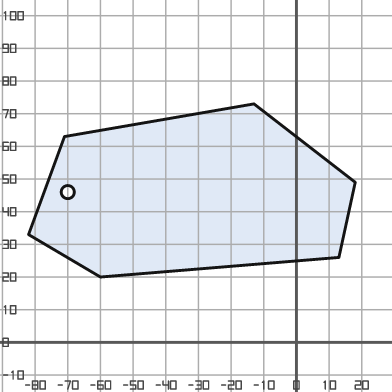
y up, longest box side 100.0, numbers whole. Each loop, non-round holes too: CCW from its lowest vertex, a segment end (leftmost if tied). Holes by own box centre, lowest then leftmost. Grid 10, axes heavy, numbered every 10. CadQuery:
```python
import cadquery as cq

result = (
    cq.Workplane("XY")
    .moveTo(-60.0, 20.0)
    .lineTo(13.0, 26.0)
    .lineTo(18.0, 49.0)
    .lineTo(-13.0, 73.0)
    .lineTo(-71.0, 63.0)
    .lineTo(-82.0, 33.0)
    .close()
    .moveTo(-70.0, 46.0)
    .circle(2.0)
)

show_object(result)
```